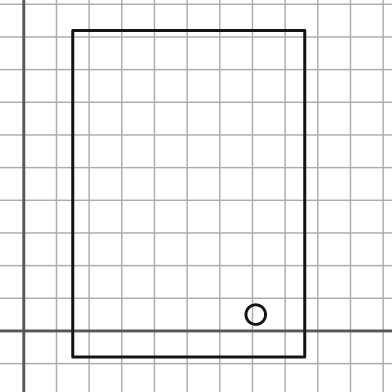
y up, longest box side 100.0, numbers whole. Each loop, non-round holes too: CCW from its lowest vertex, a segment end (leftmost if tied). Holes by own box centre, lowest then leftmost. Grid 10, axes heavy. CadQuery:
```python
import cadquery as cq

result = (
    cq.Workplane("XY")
    .moveTo(15.0, -8.0)
    .lineTo(86.0, -8.0)
    .lineTo(86.0, 92.0)
    .lineTo(15.0, 92.0)
    .close()
    .moveTo(71.0, 5.0)
    .circle(3.0)
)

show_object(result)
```